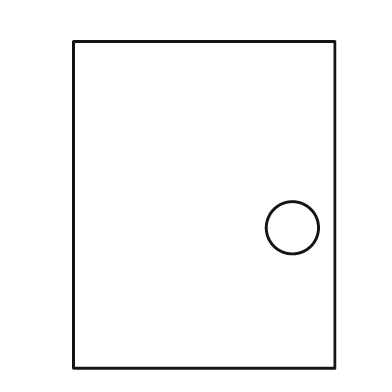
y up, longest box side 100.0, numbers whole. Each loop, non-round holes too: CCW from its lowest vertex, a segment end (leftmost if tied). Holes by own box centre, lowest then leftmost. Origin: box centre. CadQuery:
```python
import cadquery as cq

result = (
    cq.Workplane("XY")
    .moveTo(-40.0, -50.0)
    .lineTo(40.0, -50.0)
    .lineTo(40.0, 50.0)
    .lineTo(-40.0, 50.0)
    .close()
    .moveTo(27.0, -7.0)
    .circle(8.0)
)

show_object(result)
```